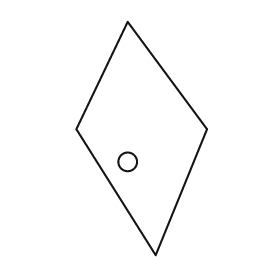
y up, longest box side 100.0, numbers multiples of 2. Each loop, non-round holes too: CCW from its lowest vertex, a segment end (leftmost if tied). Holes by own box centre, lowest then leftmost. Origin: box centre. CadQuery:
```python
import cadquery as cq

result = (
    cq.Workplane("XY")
    .moveTo(6.0, -50.0)
    .lineTo(28.0, 4.0)
    .lineTo(-6.0, 50.0)
    .lineTo(-28.0, 4.0)
    .close()
    .moveTo(-6.0, -10.0)
    .circle(4.0)
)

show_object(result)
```